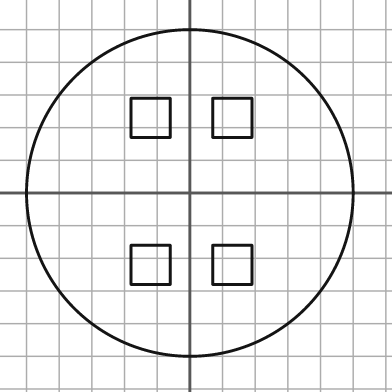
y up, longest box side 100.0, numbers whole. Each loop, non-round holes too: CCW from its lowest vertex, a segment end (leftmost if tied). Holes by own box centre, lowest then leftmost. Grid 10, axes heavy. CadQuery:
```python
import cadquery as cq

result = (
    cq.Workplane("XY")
    .moveTo(0.0, 0.0)
    .circle(50.0)
    .moveTo(-18.0, -28.0)
    .lineTo(-6.0, -28.0)
    .lineTo(-6.0, -16.0)
    .lineTo(-18.0, -16.0)
    .close()
    .moveTo(7.0, -28.0)
    .lineTo(19.0, -28.0)
    .lineTo(19.0, -16.0)
    .lineTo(7.0, -16.0)
    .close()
    .moveTo(-18.0, 17.0)
    .lineTo(-6.0, 17.0)
    .lineTo(-6.0, 29.0)
    .lineTo(-18.0, 29.0)
    .close()
    .moveTo(7.0, 17.0)
    .lineTo(19.0, 17.0)
    .lineTo(19.0, 29.0)
    .lineTo(7.0, 29.0)
    .close()
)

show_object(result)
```